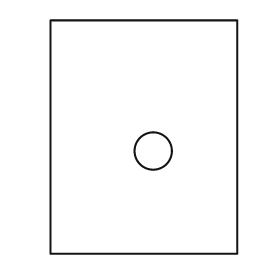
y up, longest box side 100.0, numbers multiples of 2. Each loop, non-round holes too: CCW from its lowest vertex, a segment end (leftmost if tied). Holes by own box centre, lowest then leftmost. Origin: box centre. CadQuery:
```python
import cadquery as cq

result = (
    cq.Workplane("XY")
    .moveTo(-40.0, -50.0)
    .lineTo(40.0, -50.0)
    .lineTo(40.0, 50.0)
    .lineTo(-40.0, 50.0)
    .close()
    .moveTo(4.0, -6.0)
    .circle(8.0)
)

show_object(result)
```